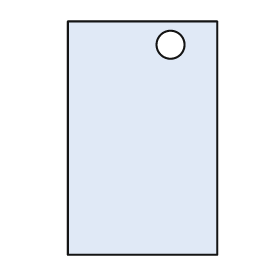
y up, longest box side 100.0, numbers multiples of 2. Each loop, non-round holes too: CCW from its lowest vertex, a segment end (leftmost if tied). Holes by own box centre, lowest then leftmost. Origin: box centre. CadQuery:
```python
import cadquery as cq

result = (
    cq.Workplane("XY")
    .moveTo(-32.0, -50.0)
    .lineTo(32.0, -50.0)
    .lineTo(32.0, 50.0)
    .lineTo(-32.0, 50.0)
    .close()
    .moveTo(12.0, 40.0)
    .circle(6.0)
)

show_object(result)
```